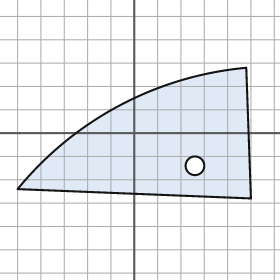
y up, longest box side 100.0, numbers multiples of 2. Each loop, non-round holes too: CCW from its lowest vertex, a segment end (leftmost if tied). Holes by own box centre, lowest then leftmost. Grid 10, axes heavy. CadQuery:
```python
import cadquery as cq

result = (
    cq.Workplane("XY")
    .moveTo(50.0, -28.0)
    .lineTo(48.0, 28.0)
    .threePointArc((-6.0, 12.0), (-50.0, -24.0))
    .close()
    .moveTo(26.0, -14.0)
    .circle(4.0)
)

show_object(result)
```